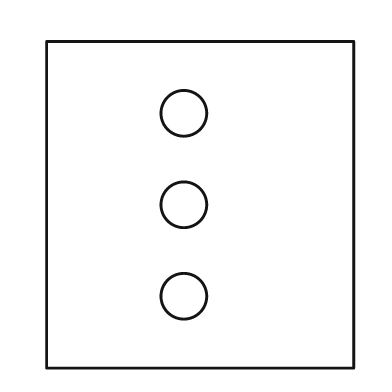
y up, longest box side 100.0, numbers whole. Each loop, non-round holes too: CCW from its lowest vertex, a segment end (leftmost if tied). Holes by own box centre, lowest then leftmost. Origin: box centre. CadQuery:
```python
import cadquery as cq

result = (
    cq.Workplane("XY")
    .moveTo(-47.0, -50.0)
    .lineTo(47.0, -50.0)
    .lineTo(47.0, 50.0)
    .lineTo(-47.0, 50.0)
    .close()
    .moveTo(-5.0, -28.0)
    .circle(7.0)
    .moveTo(-5.0, 0.0)
    .circle(7.0)
    .moveTo(-5.0, 28.0)
    .circle(7.0)
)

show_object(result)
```